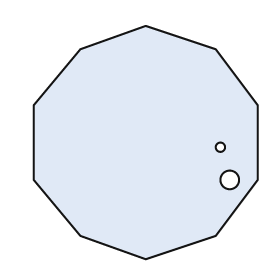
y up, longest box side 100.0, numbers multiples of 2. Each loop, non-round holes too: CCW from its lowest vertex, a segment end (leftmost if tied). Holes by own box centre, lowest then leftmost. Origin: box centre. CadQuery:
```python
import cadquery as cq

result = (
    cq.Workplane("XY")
    .moveTo(0.0, -50.0)
    .lineTo(30.0, -40.0)
    .lineTo(48.0, -16.0)
    .lineTo(48.0, 16.0)
    .lineTo(30.0, 40.0)
    .lineTo(0.0, 50.0)
    .lineTo(-28.0, 40.0)
    .lineTo(-48.0, 16.0)
    .lineTo(-48.0, -16.0)
    .lineTo(-28.0, -40.0)
    .close()
    .moveTo(36.0, -16.0)
    .circle(4.0)
    .moveTo(32.0, -2.0)
    .circle(2.0)
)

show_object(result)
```